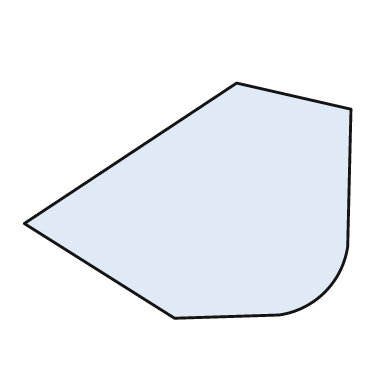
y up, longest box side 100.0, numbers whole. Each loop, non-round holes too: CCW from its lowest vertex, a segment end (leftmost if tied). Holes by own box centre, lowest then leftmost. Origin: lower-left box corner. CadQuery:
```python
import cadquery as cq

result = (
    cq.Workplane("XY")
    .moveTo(46.0, 0.0)
    .lineTo(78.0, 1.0)
    .threePointArc((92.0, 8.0), (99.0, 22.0))
    .lineTo(100.0, 64.0)
    .lineTo(65.0, 72.0)
    .lineTo(0.0, 29.0)
    .close()
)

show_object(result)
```